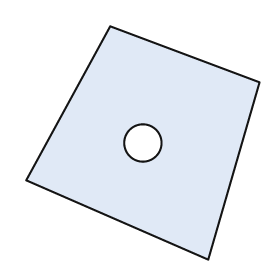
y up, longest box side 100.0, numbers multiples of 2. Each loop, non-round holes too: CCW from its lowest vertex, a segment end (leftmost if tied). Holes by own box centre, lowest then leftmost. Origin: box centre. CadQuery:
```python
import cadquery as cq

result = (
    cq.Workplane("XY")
    .moveTo(28.0, -50.0)
    .lineTo(50.0, 26.0)
    .lineTo(-14.0, 50.0)
    .lineTo(-50.0, -16.0)
    .close()
    .moveTo(0.0, 0.0)
    .circle(8.0)
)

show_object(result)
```